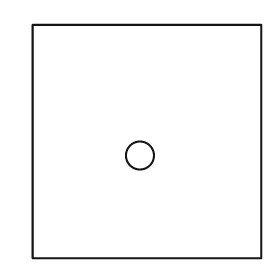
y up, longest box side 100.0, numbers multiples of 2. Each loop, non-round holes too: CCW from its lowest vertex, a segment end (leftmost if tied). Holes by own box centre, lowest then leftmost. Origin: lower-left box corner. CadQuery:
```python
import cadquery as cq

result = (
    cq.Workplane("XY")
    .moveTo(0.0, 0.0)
    .lineTo(98.0, 0.0)
    .lineTo(98.0, 100.0)
    .lineTo(0.0, 100.0)
    .close()
    .moveTo(46.0, 44.0)
    .circle(6.0)
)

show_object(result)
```